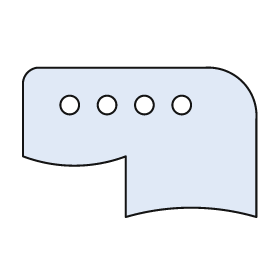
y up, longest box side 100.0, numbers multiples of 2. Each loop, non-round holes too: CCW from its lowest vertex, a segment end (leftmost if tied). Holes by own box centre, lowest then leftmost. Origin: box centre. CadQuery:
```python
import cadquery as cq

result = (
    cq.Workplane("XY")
    .moveTo(-6.0, -32.0)
    .threePointArc((22.0, -28.0), (50.0, -32.0))
    .lineTo(50.0, 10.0)
    .threePointArc((44.0, 26.0), (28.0, 32.0))
    .lineTo(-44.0, 32.0)
    .threePointArc((-48.0, 30.0), (-50.0, 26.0))
    .lineTo(-50.0, -6.0)
    .threePointArc((-28.0, -10.0), (-6.0, -6.0))
    .close()
    .moveTo(-30.0, 16.0)
    .circle(4.0)
    .moveTo(-14.0, 16.0)
    .circle(4.0)
    .moveTo(2.0, 16.0)
    .circle(4.0)
    .moveTo(18.0, 16.0)
    .circle(4.0)
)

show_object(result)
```